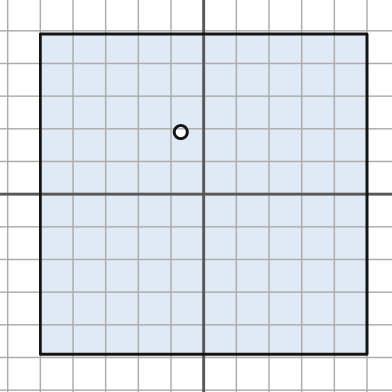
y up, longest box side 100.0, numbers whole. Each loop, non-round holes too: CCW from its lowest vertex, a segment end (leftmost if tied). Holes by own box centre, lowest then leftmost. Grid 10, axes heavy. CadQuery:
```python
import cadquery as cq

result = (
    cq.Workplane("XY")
    .moveTo(-50.0, -49.0)
    .lineTo(50.0, -49.0)
    .lineTo(50.0, 49.0)
    .lineTo(-50.0, 49.0)
    .close()
    .moveTo(-7.0, 19.0)
    .circle(2.0)
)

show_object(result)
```